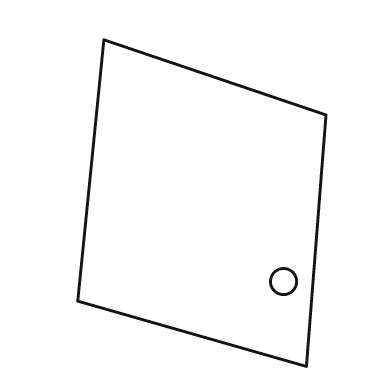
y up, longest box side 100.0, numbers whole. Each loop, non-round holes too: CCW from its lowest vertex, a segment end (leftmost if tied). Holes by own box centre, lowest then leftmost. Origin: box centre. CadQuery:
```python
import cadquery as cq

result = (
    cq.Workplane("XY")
    .moveTo(32.0, -50.0)
    .lineTo(38.0, 27.0)
    .lineTo(-30.0, 50.0)
    .lineTo(-38.0, -30.0)
    .close()
    .moveTo(25.0, -24.0)
    .circle(4.0)
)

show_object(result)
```